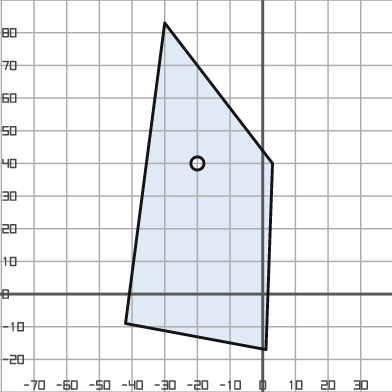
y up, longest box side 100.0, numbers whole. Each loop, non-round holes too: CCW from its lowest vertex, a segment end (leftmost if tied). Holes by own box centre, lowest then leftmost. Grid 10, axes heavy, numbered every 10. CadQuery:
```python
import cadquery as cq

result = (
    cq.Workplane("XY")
    .moveTo(1.0, -17.0)
    .lineTo(3.0, 40.0)
    .lineTo(-30.0, 83.0)
    .lineTo(-42.0, -9.0)
    .close()
    .moveTo(-20.0, 40.0)
    .circle(2.0)
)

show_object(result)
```